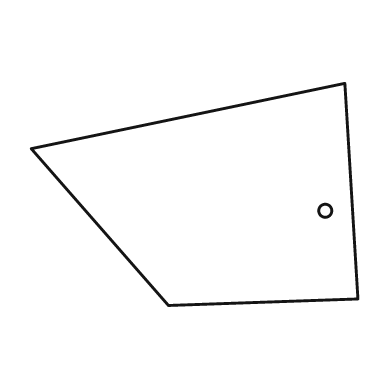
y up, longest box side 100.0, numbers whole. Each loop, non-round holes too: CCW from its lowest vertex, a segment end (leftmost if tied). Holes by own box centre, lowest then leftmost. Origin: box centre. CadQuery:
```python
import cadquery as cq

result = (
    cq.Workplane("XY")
    .moveTo(-8.0, -34.0)
    .lineTo(50.0, -32.0)
    .lineTo(46.0, 34.0)
    .lineTo(-50.0, 14.0)
    .close()
    .moveTo(40.0, -5.0)
    .circle(2.0)
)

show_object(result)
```